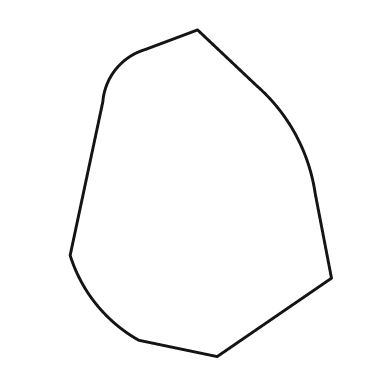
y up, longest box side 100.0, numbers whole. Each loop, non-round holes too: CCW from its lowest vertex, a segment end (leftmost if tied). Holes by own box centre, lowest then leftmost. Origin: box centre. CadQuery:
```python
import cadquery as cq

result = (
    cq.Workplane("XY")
    .moveTo(5.0, -50.0)
    .lineTo(40.0, -26.0)
    .lineTo(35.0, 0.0)
    .threePointArc((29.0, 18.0), (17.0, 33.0))
    .lineTo(-1.0, 50.0)
    .lineTo(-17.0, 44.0)
    .threePointArc((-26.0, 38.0), (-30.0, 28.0))
    .lineTo(-40.0, -19.0)
    .threePointArc((-32.0, -34.0), (-19.0, -45.0))
    .close()
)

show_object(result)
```